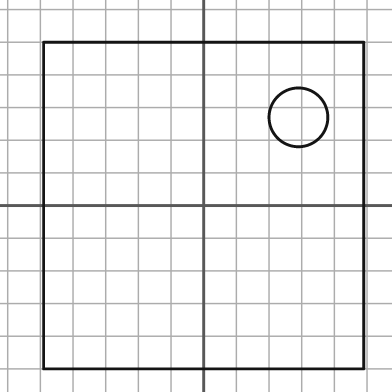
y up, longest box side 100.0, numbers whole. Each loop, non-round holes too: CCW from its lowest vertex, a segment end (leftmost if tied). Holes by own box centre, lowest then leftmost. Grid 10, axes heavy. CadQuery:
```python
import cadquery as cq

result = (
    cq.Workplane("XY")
    .moveTo(-49.0, -50.0)
    .lineTo(49.0, -50.0)
    .lineTo(49.0, 50.0)
    .lineTo(-49.0, 50.0)
    .close()
    .moveTo(29.0, 27.0)
    .circle(9.0)
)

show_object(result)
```